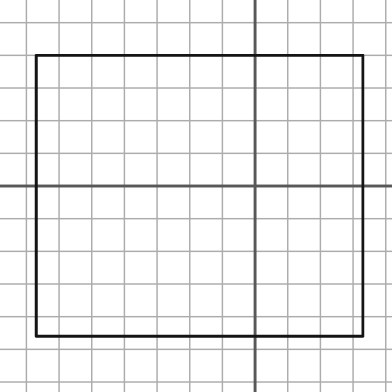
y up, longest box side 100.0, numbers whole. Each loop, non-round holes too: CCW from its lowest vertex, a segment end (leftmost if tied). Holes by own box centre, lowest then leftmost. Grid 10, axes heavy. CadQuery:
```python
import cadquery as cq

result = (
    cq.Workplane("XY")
    .moveTo(-67.0, -46.0)
    .lineTo(33.0, -46.0)
    .lineTo(33.0, 40.0)
    .lineTo(-67.0, 40.0)
    .close()
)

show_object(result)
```